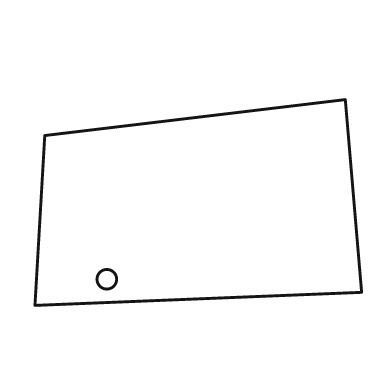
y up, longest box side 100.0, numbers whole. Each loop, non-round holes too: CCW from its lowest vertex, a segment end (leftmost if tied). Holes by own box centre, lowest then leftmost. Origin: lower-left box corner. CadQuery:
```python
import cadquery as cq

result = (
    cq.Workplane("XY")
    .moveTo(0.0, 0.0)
    .lineTo(100.0, 4.0)
    .lineTo(95.0, 63.0)
    .lineTo(3.0, 52.0)
    .close()
    .moveTo(22.0, 8.0)
    .circle(3.0)
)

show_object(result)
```